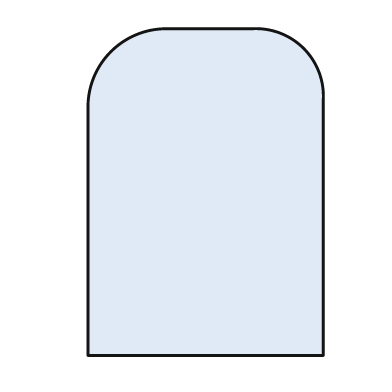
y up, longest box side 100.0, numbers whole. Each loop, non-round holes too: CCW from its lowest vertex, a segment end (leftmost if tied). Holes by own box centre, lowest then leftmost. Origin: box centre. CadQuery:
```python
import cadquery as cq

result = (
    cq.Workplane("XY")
    .moveTo(-36.0, -50.0)
    .lineTo(36.0, -50.0)
    .lineTo(36.0, 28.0)
    .threePointArc((30.0, 44.0), (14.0, 50.0))
    .lineTo(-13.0, 50.0)
    .threePointArc((-29.0, 43.0), (-36.0, 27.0))
    .close()
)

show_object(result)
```